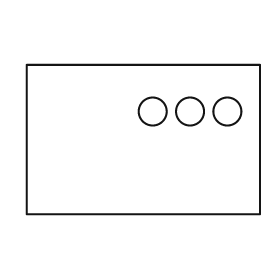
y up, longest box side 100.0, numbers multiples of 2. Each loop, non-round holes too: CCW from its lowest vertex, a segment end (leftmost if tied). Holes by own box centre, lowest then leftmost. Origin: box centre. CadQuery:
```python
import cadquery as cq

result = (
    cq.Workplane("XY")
    .moveTo(-50.0, -32.0)
    .lineTo(50.0, -32.0)
    .lineTo(50.0, 32.0)
    .lineTo(-50.0, 32.0)
    .close()
    .moveTo(4.0, 12.0)
    .circle(6.0)
    .moveTo(20.0, 12.0)
    .circle(6.0)
    .moveTo(36.0, 12.0)
    .circle(6.0)
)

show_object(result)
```